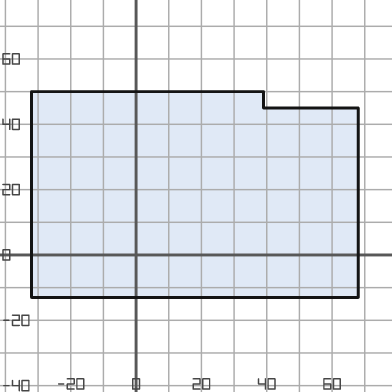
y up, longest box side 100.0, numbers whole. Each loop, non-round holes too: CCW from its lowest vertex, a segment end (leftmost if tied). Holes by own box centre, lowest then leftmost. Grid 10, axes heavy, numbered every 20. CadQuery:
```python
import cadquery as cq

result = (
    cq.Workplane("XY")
    .moveTo(-32.0, -13.0)
    .lineTo(68.0, -13.0)
    .lineTo(68.0, 45.0)
    .lineTo(39.0, 45.0)
    .lineTo(39.0, 50.0)
    .lineTo(-32.0, 50.0)
    .close()
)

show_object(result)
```